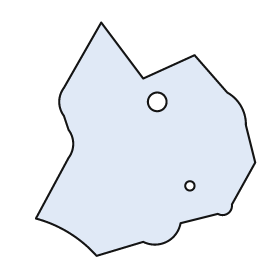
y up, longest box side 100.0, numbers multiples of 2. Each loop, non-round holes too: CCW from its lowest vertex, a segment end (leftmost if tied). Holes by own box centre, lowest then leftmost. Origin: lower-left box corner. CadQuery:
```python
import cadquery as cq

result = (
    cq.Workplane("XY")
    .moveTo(26.0, 0.0)
    .lineTo(46.0, 6.0)
    .threePointArc((56.0, 6.0), (62.0, 14.0))
    .lineTo(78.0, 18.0)
    .threePointArc((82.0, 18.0), (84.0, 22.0))
    .lineTo(94.0, 40.0)
    .lineTo(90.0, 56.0)
    .threePointArc((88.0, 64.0), (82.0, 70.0))
    .lineTo(68.0, 86.0)
    .lineTo(46.0, 76.0)
    .lineTo(28.0, 100.0)
    .lineTo(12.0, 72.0)
    .threePointArc((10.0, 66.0), (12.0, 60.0))
    .lineTo(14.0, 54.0)
    .threePointArc((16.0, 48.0), (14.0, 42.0))
    .lineTo(0.0, 16.0)
    .threePointArc((14.0, 10.0), (26.0, 0.0))
    .close()
    .moveTo(66.0, 30.0)
    .circle(2.0)
    .moveTo(52.0, 66.0)
    .circle(4.0)
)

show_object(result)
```